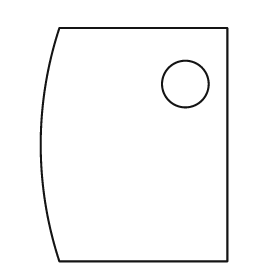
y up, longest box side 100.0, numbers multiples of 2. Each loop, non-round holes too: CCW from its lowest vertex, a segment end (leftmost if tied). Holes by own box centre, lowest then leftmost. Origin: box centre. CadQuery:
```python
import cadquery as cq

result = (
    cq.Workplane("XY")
    .moveTo(-32.0, -50.0)
    .lineTo(40.0, -50.0)
    .lineTo(40.0, 50.0)
    .lineTo(-32.0, 50.0)
    .threePointArc((-40.0, 0.0), (-32.0, -50.0))
    .close()
    .moveTo(22.0, 26.0)
    .circle(10.0)
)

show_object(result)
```